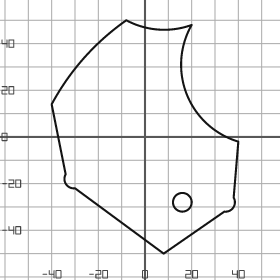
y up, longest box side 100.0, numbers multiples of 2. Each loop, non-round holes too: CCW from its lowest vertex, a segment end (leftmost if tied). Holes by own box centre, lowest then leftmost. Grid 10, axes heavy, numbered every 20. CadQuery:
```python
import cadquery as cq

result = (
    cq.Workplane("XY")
    .moveTo(8.0, -50.0)
    .lineTo(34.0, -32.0)
    .threePointArc((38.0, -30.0), (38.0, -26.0))
    .lineTo(40.0, -2.0)
    .threePointArc((18.0, 18.0), (20.0, 48.0))
    .threePointArc((6.0, 46.0), (-8.0, 50.0))
    .threePointArc((-26.0, 34.0), (-40.0, 14.0))
    .lineTo(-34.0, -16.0)
    .threePointArc((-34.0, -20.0), (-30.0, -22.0))
    .close()
    .moveTo(16.0, -28.0)
    .circle(4.0)
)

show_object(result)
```